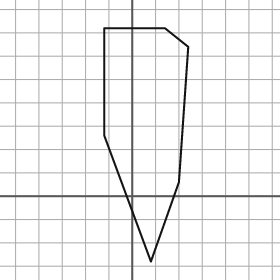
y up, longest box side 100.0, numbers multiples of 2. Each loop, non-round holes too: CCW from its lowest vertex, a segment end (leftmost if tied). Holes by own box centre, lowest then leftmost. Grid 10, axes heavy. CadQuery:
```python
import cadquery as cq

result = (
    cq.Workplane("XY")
    .moveTo(8.0, -28.0)
    .lineTo(20.0, 6.0)
    .lineTo(24.0, 64.0)
    .lineTo(14.0, 72.0)
    .lineTo(-12.0, 72.0)
    .lineTo(-12.0, 26.0)
    .close()
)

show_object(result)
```